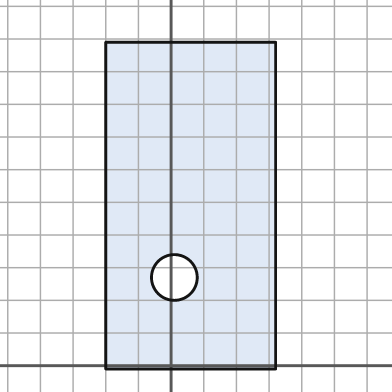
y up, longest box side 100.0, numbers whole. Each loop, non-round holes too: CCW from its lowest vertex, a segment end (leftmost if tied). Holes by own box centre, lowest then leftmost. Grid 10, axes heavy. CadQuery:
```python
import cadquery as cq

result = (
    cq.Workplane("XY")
    .moveTo(-20.0, -1.0)
    .lineTo(32.0, -1.0)
    .lineTo(32.0, 99.0)
    .lineTo(-20.0, 99.0)
    .close()
    .moveTo(1.0, 27.0)
    .circle(7.0)
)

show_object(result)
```